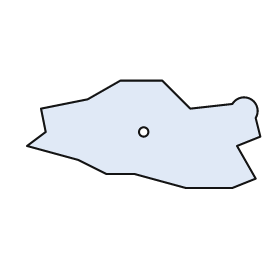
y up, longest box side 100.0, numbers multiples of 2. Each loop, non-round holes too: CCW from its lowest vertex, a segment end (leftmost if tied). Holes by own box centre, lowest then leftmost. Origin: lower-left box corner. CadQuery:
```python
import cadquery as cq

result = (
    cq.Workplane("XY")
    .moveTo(68.0, 0.0)
    .lineTo(88.0, 0.0)
    .lineTo(98.0, 4.0)
    .lineTo(90.0, 18.0)
    .lineTo(100.0, 22.0)
    .lineTo(98.0, 30.0)
    .threePointArc((96.0, 38.0), (88.0, 36.0))
    .lineTo(70.0, 34.0)
    .lineTo(58.0, 46.0)
    .lineTo(40.0, 46.0)
    .lineTo(26.0, 38.0)
    .lineTo(6.0, 34.0)
    .lineTo(8.0, 24.0)
    .lineTo(0.0, 18.0)
    .lineTo(22.0, 12.0)
    .lineTo(34.0, 6.0)
    .lineTo(46.0, 6.0)
    .close()
    .moveTo(50.0, 24.0)
    .circle(2.0)
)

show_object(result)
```